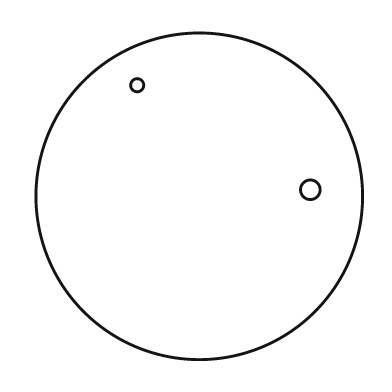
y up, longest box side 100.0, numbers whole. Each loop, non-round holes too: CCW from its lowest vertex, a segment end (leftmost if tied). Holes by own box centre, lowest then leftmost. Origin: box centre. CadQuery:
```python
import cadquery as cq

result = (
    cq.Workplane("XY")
    .moveTo(0.0, 0.0)
    .circle(50.0)
    .moveTo(34.0, 2.0)
    .circle(3.0)
    .moveTo(-19.0, 34.0)
    .circle(2.0)
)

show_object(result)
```